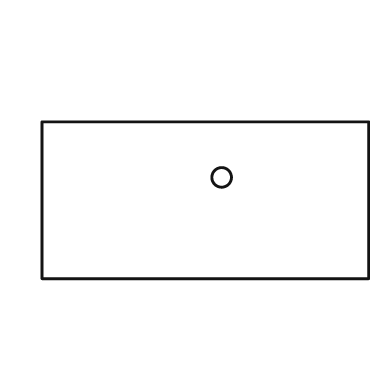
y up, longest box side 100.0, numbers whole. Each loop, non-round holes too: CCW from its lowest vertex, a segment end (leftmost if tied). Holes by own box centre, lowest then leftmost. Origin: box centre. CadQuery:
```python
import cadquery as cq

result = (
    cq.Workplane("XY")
    .moveTo(-50.0, -24.0)
    .lineTo(50.0, -24.0)
    .lineTo(50.0, 24.0)
    .lineTo(-50.0, 24.0)
    .close()
    .moveTo(5.0, 7.0)
    .circle(3.0)
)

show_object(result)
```